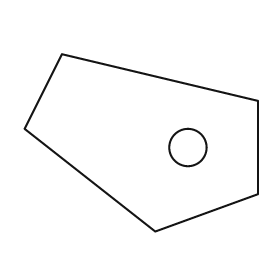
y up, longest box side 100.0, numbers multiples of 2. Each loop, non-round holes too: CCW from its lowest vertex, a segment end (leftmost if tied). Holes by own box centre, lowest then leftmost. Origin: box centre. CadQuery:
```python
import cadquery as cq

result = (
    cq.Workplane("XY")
    .moveTo(6.0, -38.0)
    .lineTo(50.0, -22.0)
    .lineTo(50.0, 18.0)
    .lineTo(-34.0, 38.0)
    .lineTo(-50.0, 6.0)
    .close()
    .moveTo(20.0, -2.0)
    .circle(8.0)
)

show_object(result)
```